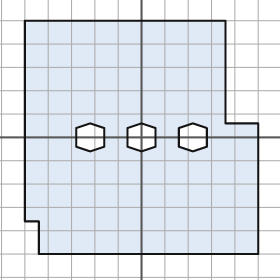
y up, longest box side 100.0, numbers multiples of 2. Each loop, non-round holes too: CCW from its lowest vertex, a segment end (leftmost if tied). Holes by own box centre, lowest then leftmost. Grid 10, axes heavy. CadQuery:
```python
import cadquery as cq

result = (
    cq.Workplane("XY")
    .moveTo(-44.0, -50.0)
    .lineTo(50.0, -50.0)
    .lineTo(50.0, 6.0)
    .lineTo(36.0, 6.0)
    .lineTo(36.0, 50.0)
    .lineTo(-50.0, 50.0)
    .lineTo(-50.0, -36.0)
    .lineTo(-44.0, -36.0)
    .close()
    .moveTo(-22.0, -6.0)
    .lineTo(-16.0, -4.0)
    .lineTo(-16.0, 4.0)
    .lineTo(-22.0, 6.0)
    .lineTo(-28.0, 4.0)
    .lineTo(-28.0, -4.0)
    .close()
    .moveTo(0.0, -6.0)
    .lineTo(6.0, -4.0)
    .lineTo(6.0, 4.0)
    .lineTo(0.0, 6.0)
    .lineTo(-6.0, 4.0)
    .lineTo(-6.0, -4.0)
    .close()
    .moveTo(22.0, -6.0)
    .lineTo(28.0, -4.0)
    .lineTo(28.0, 4.0)
    .lineTo(22.0, 6.0)
    .lineTo(16.0, 4.0)
    .lineTo(16.0, -4.0)
    .close()
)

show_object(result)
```